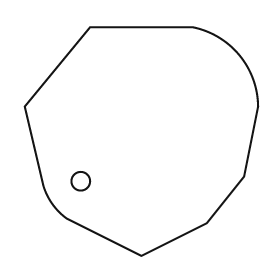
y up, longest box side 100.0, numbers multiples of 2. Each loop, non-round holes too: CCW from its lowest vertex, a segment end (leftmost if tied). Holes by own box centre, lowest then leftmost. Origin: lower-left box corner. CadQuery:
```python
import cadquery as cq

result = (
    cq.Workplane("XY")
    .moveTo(50.0, 0.0)
    .lineTo(78.0, 14.0)
    .lineTo(94.0, 34.0)
    .lineTo(100.0, 64.0)
    .threePointArc((92.0, 86.0), (72.0, 98.0))
    .lineTo(28.0, 98.0)
    .lineTo(0.0, 64.0)
    .lineTo(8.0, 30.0)
    .threePointArc((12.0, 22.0), (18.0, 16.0))
    .close()
    .moveTo(24.0, 32.0)
    .circle(4.0)
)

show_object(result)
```